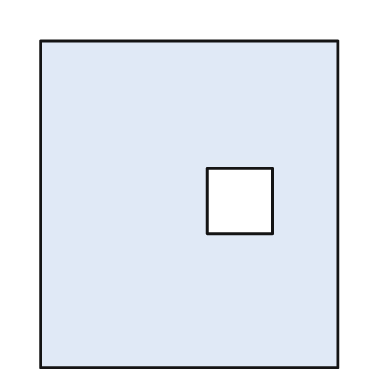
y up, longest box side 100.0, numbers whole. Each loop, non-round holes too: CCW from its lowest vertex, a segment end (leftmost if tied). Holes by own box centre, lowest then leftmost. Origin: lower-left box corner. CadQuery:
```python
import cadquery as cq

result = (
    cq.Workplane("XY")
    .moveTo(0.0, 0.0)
    .lineTo(91.0, 0.0)
    .lineTo(91.0, 100.0)
    .lineTo(0.0, 100.0)
    .close()
    .moveTo(51.0, 41.0)
    .lineTo(71.0, 41.0)
    .lineTo(71.0, 61.0)
    .lineTo(51.0, 61.0)
    .close()
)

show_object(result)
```